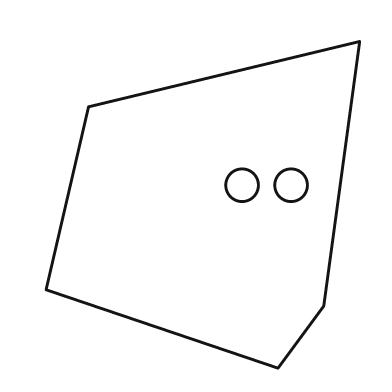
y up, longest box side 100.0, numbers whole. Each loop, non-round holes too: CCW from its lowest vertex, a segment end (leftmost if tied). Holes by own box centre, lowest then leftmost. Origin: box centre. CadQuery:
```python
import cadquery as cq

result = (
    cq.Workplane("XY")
    .moveTo(23.0, -50.0)
    .lineTo(37.0, -31.0)
    .lineTo(48.0, 50.0)
    .lineTo(-35.0, 30.0)
    .lineTo(-48.0, -26.0)
    .close()
    .moveTo(12.0, 6.0)
    .circle(5.0)
    .moveTo(27.0, 6.0)
    .circle(5.0)
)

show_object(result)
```